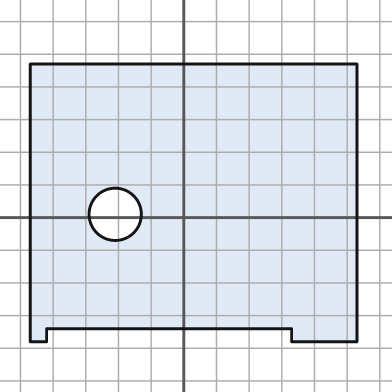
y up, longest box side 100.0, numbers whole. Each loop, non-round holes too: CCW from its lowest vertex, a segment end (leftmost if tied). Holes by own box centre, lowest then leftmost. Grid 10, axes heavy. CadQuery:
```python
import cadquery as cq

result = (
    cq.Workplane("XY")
    .moveTo(-47.0, -38.0)
    .lineTo(-42.0, -38.0)
    .lineTo(-42.0, -34.0)
    .lineTo(33.0, -34.0)
    .lineTo(33.0, -38.0)
    .lineTo(53.0, -38.0)
    .lineTo(53.0, 47.0)
    .lineTo(-47.0, 47.0)
    .close()
    .moveTo(-21.0, 1.0)
    .circle(8.0)
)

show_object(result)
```